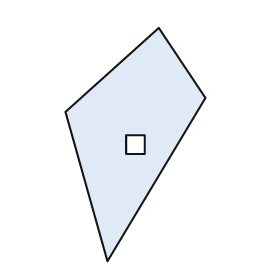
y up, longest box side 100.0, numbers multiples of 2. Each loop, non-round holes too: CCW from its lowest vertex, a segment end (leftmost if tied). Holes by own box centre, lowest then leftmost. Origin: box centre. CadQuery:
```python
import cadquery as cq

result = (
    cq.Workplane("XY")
    .moveTo(-12.0, -50.0)
    .lineTo(30.0, 20.0)
    .lineTo(10.0, 50.0)
    .lineTo(-30.0, 14.0)
    .close()
    .moveTo(-4.0, -4.0)
    .lineTo(4.0, -4.0)
    .lineTo(4.0, 4.0)
    .lineTo(-4.0, 4.0)
    .close()
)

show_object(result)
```